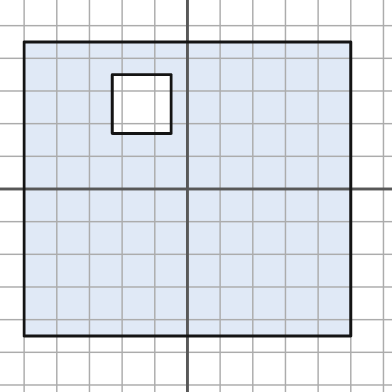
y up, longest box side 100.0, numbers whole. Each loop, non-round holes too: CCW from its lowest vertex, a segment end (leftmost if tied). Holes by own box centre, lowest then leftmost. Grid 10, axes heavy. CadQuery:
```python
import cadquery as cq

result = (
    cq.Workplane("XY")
    .moveTo(-50.0, -45.0)
    .lineTo(50.0, -45.0)
    .lineTo(50.0, 45.0)
    .lineTo(-50.0, 45.0)
    .close()
    .moveTo(-23.0, 17.0)
    .lineTo(-5.0, 17.0)
    .lineTo(-5.0, 35.0)
    .lineTo(-23.0, 35.0)
    .close()
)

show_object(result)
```